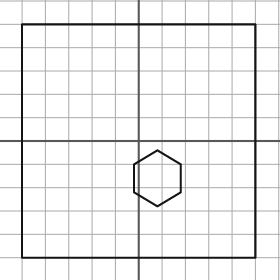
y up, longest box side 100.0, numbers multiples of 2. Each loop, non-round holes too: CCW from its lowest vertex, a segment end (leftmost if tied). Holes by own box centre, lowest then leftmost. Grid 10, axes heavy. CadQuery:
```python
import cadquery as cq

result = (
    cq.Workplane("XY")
    .moveTo(-50.0, -50.0)
    .lineTo(50.0, -50.0)
    .lineTo(50.0, 50.0)
    .lineTo(-50.0, 50.0)
    .close()
    .moveTo(8.0, -28.0)
    .lineTo(18.0, -22.0)
    .lineTo(18.0, -10.0)
    .lineTo(8.0, -4.0)
    .lineTo(-2.0, -10.0)
    .lineTo(-2.0, -22.0)
    .close()
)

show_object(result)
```